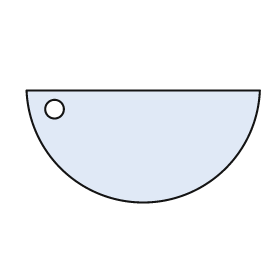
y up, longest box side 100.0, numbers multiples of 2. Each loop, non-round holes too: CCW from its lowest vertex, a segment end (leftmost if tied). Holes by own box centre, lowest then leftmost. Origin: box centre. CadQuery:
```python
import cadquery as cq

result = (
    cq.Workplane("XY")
    .moveTo(-50.0, 24.0)
    .threePointArc((0.0, -24.0), (50.0, 24.0))
    .close()
    .moveTo(-38.0, 16.0)
    .circle(4.0)
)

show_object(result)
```